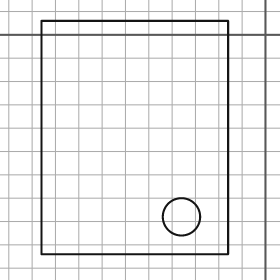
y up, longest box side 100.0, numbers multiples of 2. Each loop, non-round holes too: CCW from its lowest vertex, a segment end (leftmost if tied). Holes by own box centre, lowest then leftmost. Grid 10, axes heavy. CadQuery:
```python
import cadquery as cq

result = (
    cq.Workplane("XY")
    .moveTo(-96.0, -94.0)
    .lineTo(-16.0, -94.0)
    .lineTo(-16.0, 6.0)
    .lineTo(-96.0, 6.0)
    .close()
    .moveTo(-36.0, -78.0)
    .circle(8.0)
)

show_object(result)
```